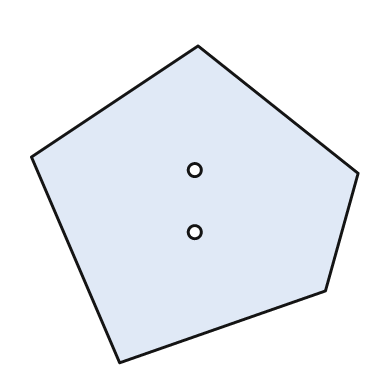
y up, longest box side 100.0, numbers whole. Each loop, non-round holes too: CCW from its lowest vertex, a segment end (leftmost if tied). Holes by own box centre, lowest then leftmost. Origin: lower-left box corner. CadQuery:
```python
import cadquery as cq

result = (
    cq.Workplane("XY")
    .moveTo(27.0, 0.0)
    .lineTo(90.0, 22.0)
    .lineTo(100.0, 58.0)
    .lineTo(51.0, 97.0)
    .lineTo(0.0, 63.0)
    .close()
    .moveTo(50.0, 40.0)
    .circle(2.0)
    .moveTo(50.0, 59.0)
    .circle(2.0)
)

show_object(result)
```